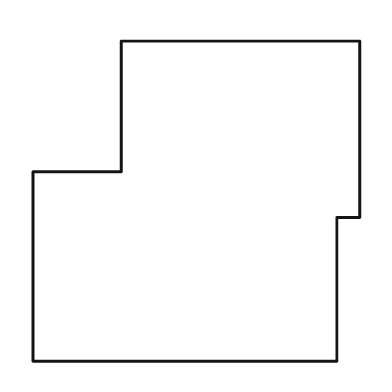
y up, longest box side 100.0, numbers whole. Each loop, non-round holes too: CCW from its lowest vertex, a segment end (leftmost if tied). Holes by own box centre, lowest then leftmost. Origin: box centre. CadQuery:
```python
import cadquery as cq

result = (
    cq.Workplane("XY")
    .moveTo(-50.0, -49.0)
    .lineTo(43.0, -49.0)
    .lineTo(43.0, -5.0)
    .lineTo(50.0, -5.0)
    .lineTo(50.0, 49.0)
    .lineTo(-23.0, 49.0)
    .lineTo(-23.0, 9.0)
    .lineTo(-50.0, 9.0)
    .close()
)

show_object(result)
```